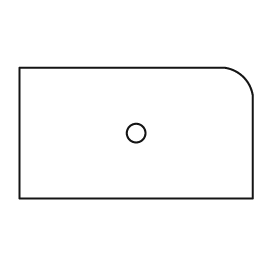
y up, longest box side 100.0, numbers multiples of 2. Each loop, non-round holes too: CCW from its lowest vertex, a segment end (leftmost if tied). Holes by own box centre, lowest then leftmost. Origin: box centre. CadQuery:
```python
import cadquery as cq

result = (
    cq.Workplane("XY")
    .moveTo(-50.0, -28.0)
    .lineTo(50.0, -28.0)
    .lineTo(50.0, 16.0)
    .threePointArc((46.0, 24.0), (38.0, 28.0))
    .lineTo(-50.0, 28.0)
    .close()
    .moveTo(0.0, 0.0)
    .circle(4.0)
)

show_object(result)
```